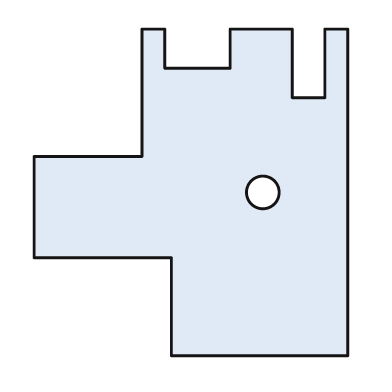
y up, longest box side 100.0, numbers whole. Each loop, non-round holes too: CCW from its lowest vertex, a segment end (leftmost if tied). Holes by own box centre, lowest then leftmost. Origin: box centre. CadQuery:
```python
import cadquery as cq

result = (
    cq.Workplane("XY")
    .moveTo(-6.0, -50.0)
    .lineTo(48.0, -50.0)
    .lineTo(48.0, 50.0)
    .lineTo(41.0, 50.0)
    .lineTo(41.0, 29.0)
    .lineTo(31.0, 29.0)
    .lineTo(31.0, 50.0)
    .lineTo(12.0, 50.0)
    .lineTo(12.0, 38.0)
    .lineTo(-8.0, 38.0)
    .lineTo(-8.0, 50.0)
    .lineTo(-15.0, 50.0)
    .lineTo(-15.0, 11.0)
    .lineTo(-48.0, 11.0)
    .lineTo(-48.0, -20.0)
    .lineTo(-6.0, -20.0)
    .close()
    .moveTo(22.0, 0.0)
    .circle(5.0)
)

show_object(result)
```